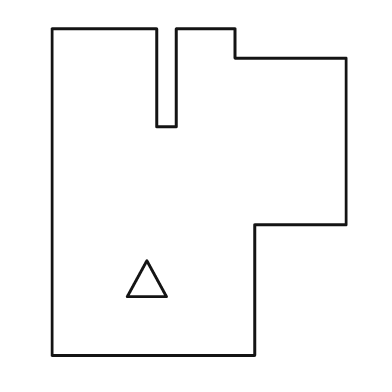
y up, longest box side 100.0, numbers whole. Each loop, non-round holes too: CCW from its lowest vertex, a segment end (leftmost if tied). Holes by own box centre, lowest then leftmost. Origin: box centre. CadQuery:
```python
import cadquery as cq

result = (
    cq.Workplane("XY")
    .moveTo(-45.0, -50.0)
    .lineTo(17.0, -50.0)
    .lineTo(17.0, -10.0)
    .lineTo(45.0, -10.0)
    .lineTo(45.0, 41.0)
    .lineTo(11.0, 41.0)
    .lineTo(11.0, 50.0)
    .lineTo(-7.0, 50.0)
    .lineTo(-7.0, 20.0)
    .lineTo(-13.0, 20.0)
    .lineTo(-13.0, 50.0)
    .lineTo(-45.0, 50.0)
    .close()
    .moveTo(-22.0, -32.0)
    .lineTo(-10.0, -32.0)
    .lineTo(-16.0, -21.0)
    .close()
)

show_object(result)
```